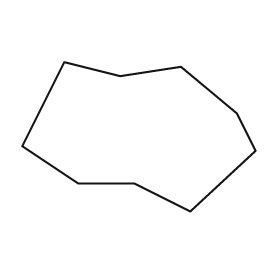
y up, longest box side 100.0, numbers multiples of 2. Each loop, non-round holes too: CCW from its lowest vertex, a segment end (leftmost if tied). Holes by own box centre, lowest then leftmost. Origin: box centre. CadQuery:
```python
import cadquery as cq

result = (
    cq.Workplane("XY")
    .moveTo(22.0, -32.0)
    .lineTo(50.0, -6.0)
    .lineTo(42.0, 10.0)
    .lineTo(18.0, 30.0)
    .lineTo(-8.0, 26.0)
    .lineTo(-32.0, 32.0)
    .lineTo(-50.0, -4.0)
    .lineTo(-26.0, -20.0)
    .lineTo(-2.0, -20.0)
    .close()
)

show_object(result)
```